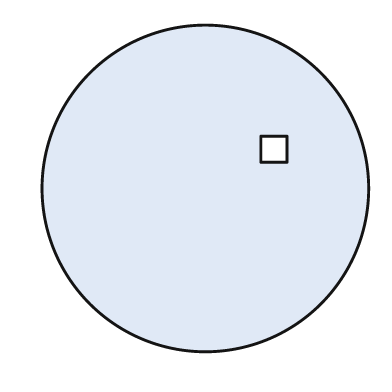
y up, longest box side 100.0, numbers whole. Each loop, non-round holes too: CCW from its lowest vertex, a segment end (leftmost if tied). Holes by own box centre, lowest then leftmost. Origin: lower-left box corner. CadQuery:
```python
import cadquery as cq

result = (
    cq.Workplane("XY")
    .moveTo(50.0, 50.0)
    .circle(50.0)
    .moveTo(67.0, 58.0)
    .lineTo(75.0, 58.0)
    .lineTo(75.0, 66.0)
    .lineTo(67.0, 66.0)
    .close()
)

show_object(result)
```